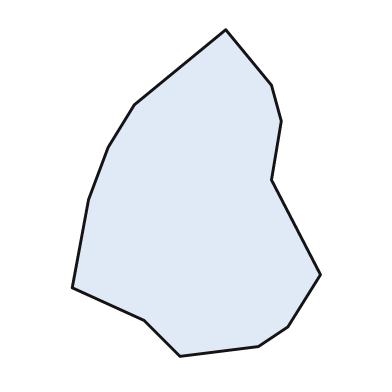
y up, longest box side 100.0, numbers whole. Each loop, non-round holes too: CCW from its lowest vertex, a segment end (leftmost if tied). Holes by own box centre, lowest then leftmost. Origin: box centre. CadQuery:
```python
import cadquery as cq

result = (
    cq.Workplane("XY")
    .moveTo(-5.0, -50.0)
    .lineTo(19.0, -47.0)
    .lineTo(28.0, -41.0)
    .lineTo(38.0, -25.0)
    .lineTo(23.0, 4.0)
    .lineTo(26.0, 22.0)
    .lineTo(23.0, 33.0)
    .lineTo(9.0, 50.0)
    .lineTo(-19.0, 27.0)
    .lineTo(-27.0, 14.0)
    .lineTo(-33.0, -2.0)
    .lineTo(-38.0, -29.0)
    .lineTo(-16.0, -39.0)
    .close()
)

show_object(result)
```